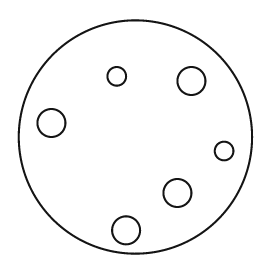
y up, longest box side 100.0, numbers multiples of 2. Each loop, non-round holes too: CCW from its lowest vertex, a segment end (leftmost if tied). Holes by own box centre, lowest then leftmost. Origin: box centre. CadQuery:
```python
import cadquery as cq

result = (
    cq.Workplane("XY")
    .moveTo(0.0, 0.0)
    .circle(50.0)
    .moveTo(-4.0, -40.0)
    .circle(6.0)
    .moveTo(18.0, -24.0)
    .circle(6.0)
    .moveTo(38.0, -6.0)
    .circle(4.0)
    .moveTo(-36.0, 6.0)
    .circle(6.0)
    .moveTo(24.0, 24.0)
    .circle(6.0)
    .moveTo(-8.0, 26.0)
    .circle(4.0)
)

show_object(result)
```